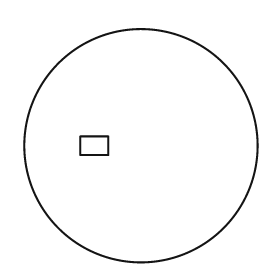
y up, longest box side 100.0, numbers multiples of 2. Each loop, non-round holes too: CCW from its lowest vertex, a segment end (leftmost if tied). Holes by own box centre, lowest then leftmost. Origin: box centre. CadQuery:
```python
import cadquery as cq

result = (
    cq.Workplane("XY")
    .moveTo(0.0, 0.0)
    .circle(50.0)
    .moveTo(-26.0, -4.0)
    .lineTo(-14.0, -4.0)
    .lineTo(-14.0, 4.0)
    .lineTo(-26.0, 4.0)
    .close()
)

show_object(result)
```